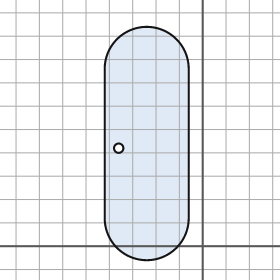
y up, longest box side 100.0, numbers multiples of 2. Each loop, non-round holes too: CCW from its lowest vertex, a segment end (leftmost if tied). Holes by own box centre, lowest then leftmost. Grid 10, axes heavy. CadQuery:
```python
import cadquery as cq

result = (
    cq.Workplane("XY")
    .moveTo(-42.0, 12.0)
    .threePointArc((-24.0, -6.0), (-6.0, 12.0))
    .lineTo(-6.0, 76.0)
    .threePointArc((-24.0, 94.0), (-42.0, 76.0))
    .close()
    .moveTo(-36.0, 42.0)
    .circle(2.0)
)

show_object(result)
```